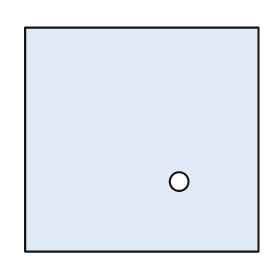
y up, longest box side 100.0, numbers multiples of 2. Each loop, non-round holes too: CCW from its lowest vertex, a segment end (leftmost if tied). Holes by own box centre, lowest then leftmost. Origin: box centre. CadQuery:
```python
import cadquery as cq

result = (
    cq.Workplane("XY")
    .moveTo(-50.0, -48.0)
    .lineTo(50.0, -48.0)
    .lineTo(50.0, 48.0)
    .lineTo(-50.0, 48.0)
    .close()
    .moveTo(16.0, -18.0)
    .circle(4.0)
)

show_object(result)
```